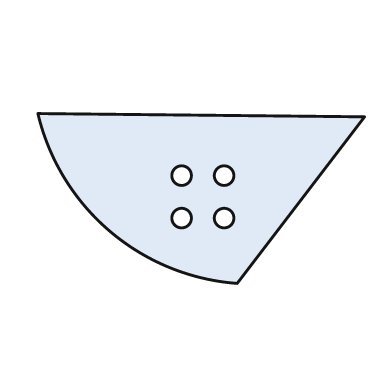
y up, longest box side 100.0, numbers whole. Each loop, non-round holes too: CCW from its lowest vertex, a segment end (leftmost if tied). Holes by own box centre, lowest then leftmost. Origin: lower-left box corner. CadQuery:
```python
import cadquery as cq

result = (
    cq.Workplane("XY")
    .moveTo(61.0, 0.0)
    .lineTo(100.0, 51.0)
    .lineTo(0.0, 52.0)
    .threePointArc((22.0, 16.0), (61.0, 0.0))
    .close()
    .moveTo(44.0, 20.0)
    .circle(3.0)
    .moveTo(57.0, 20.0)
    .circle(3.0)
    .moveTo(44.0, 33.0)
    .circle(3.0)
    .moveTo(57.0, 33.0)
    .circle(3.0)
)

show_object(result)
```